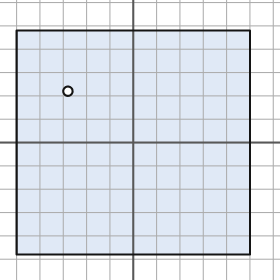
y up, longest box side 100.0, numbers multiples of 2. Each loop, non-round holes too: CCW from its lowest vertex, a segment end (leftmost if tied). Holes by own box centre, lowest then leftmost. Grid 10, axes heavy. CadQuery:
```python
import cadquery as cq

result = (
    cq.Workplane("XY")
    .moveTo(-50.0, -48.0)
    .lineTo(50.0, -48.0)
    .lineTo(50.0, 48.0)
    .lineTo(-50.0, 48.0)
    .close()
    .moveTo(-28.0, 22.0)
    .circle(2.0)
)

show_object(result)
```